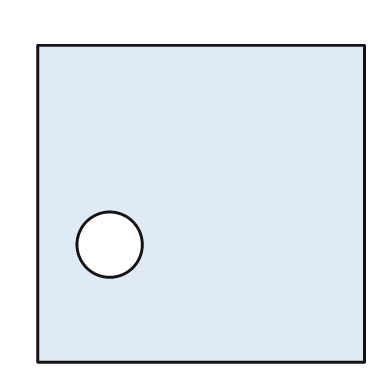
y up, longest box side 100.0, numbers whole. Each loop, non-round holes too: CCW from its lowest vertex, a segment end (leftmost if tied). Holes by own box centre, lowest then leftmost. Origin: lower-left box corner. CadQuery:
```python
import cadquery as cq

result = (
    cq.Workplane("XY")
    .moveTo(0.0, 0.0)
    .lineTo(100.0, 0.0)
    .lineTo(100.0, 97.0)
    .lineTo(0.0, 97.0)
    .close()
    .moveTo(22.0, 36.0)
    .circle(10.0)
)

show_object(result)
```